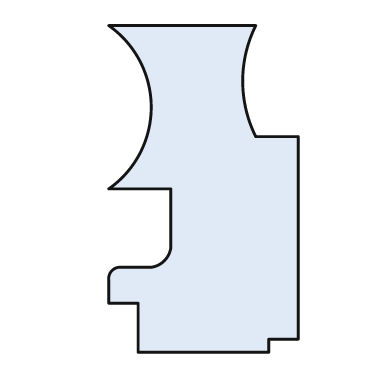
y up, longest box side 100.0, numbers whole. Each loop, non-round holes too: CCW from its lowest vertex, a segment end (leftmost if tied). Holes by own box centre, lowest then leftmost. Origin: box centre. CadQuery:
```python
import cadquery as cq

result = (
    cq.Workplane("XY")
    .moveTo(-20.0, -50.0)
    .lineTo(20.0, -50.0)
    .lineTo(20.0, -46.0)
    .lineTo(29.0, -46.0)
    .lineTo(29.0, 16.0)
    .lineTo(16.0, 16.0)
    .threePointArc((12.0, 33.0), (16.0, 50.0))
    .lineTo(-29.0, 50.0)
    .threePointArc((-16.0, 25.0), (-29.0, 0.0))
    .lineTo(-10.0, 0.0)
    .lineTo(-10.0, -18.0)
    .threePointArc((-12.0, -22.0), (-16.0, -24.0))
    .lineTo(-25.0, -24.0)
    .threePointArc((-28.0, -25.0), (-29.0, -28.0))
    .lineTo(-29.0, -35.0)
    .lineTo(-20.0, -35.0)
    .close()
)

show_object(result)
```